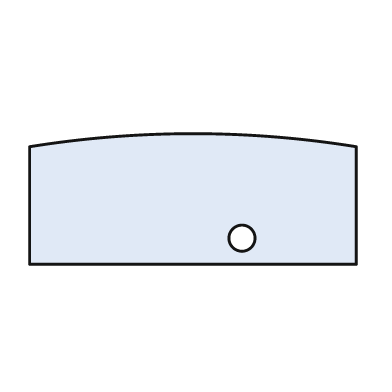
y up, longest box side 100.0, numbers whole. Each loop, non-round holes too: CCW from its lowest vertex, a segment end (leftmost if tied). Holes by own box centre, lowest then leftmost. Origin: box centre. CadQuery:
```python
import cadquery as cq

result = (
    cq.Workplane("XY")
    .moveTo(-50.0, -20.0)
    .lineTo(50.0, -20.0)
    .lineTo(50.0, 16.0)
    .threePointArc((0.0, 20.0), (-50.0, 16.0))
    .close()
    .moveTo(15.0, -12.0)
    .circle(4.0)
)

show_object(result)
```